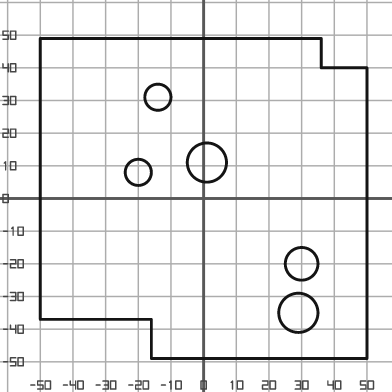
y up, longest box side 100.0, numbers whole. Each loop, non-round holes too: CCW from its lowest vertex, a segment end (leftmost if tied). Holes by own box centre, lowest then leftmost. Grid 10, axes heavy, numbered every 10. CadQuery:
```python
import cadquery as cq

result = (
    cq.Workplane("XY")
    .moveTo(-16.0, -49.0)
    .lineTo(50.0, -49.0)
    .lineTo(50.0, 40.0)
    .lineTo(36.0, 40.0)
    .lineTo(36.0, 49.0)
    .lineTo(-50.0, 49.0)
    .lineTo(-50.0, -37.0)
    .lineTo(-16.0, -37.0)
    .close()
    .moveTo(29.0, -35.0)
    .circle(6.0)
    .moveTo(30.0, -20.0)
    .circle(5.0)
    .moveTo(-20.0, 8.0)
    .circle(4.0)
    .moveTo(1.0, 11.0)
    .circle(6.0)
    .moveTo(-14.0, 31.0)
    .circle(4.0)
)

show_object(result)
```